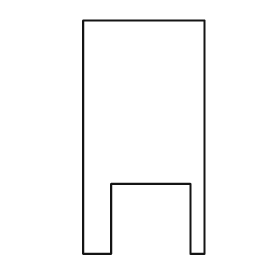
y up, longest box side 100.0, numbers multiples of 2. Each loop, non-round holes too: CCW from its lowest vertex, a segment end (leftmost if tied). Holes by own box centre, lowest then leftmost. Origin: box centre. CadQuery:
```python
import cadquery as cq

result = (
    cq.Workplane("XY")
    .moveTo(-26.0, -50.0)
    .lineTo(-14.0, -50.0)
    .lineTo(-14.0, -20.0)
    .lineTo(20.0, -20.0)
    .lineTo(20.0, -50.0)
    .lineTo(26.0, -50.0)
    .lineTo(26.0, 50.0)
    .lineTo(-26.0, 50.0)
    .close()
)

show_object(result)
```